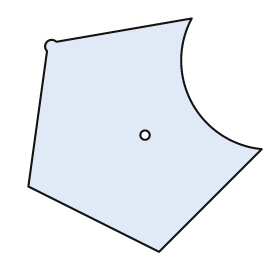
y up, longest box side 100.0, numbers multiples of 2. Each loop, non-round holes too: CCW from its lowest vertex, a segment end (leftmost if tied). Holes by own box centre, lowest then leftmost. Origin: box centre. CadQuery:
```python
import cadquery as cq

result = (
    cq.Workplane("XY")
    .moveTo(6.0, -50.0)
    .lineTo(50.0, -6.0)
    .threePointArc((20.0, 14.0), (20.0, 50.0))
    .lineTo(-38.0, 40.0)
    .threePointArc((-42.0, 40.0), (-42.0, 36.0))
    .lineTo(-50.0, -22.0)
    .close()
    .moveTo(0.0, 0.0)
    .circle(2.0)
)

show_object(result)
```